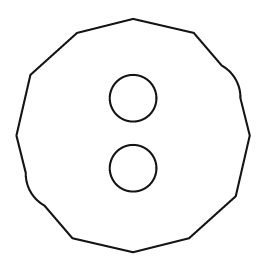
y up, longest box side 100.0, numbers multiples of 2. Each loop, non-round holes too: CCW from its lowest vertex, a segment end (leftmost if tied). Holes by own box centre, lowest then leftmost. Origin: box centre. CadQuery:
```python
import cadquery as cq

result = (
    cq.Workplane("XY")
    .moveTo(0.0, -50.0)
    .lineTo(24.0, -44.0)
    .lineTo(44.0, -26.0)
    .lineTo(50.0, 0.0)
    .lineTo(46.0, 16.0)
    .threePointArc((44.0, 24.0), (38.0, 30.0))
    .lineTo(26.0, 44.0)
    .lineTo(0.0, 50.0)
    .lineTo(-24.0, 44.0)
    .lineTo(-44.0, 26.0)
    .lineTo(-50.0, 0.0)
    .lineTo(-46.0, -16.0)
    .threePointArc((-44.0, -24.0), (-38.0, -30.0))
    .lineTo(-26.0, -44.0)
    .close()
    .moveTo(0.0, -14.0)
    .circle(10.0)
    .moveTo(0.0, 16.0)
    .circle(10.0)
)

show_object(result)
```